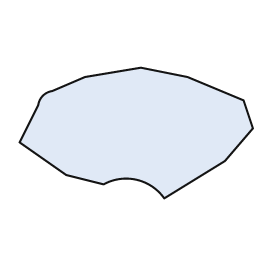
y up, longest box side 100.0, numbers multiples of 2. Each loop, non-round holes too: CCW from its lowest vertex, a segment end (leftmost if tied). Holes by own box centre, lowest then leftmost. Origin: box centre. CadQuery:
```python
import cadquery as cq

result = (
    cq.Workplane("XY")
    .moveTo(12.0, -28.0)
    .lineTo(38.0, -12.0)
    .lineTo(50.0, 2.0)
    .lineTo(46.0, 14.0)
    .lineTo(22.0, 24.0)
    .lineTo(2.0, 28.0)
    .lineTo(-22.0, 24.0)
    .lineTo(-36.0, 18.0)
    .threePointArc((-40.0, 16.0), (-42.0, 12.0))
    .lineTo(-50.0, -4.0)
    .lineTo(-30.0, -18.0)
    .lineTo(-14.0, -22.0)
    .threePointArc((0.0, -20.0), (12.0, -28.0))
    .close()
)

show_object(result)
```